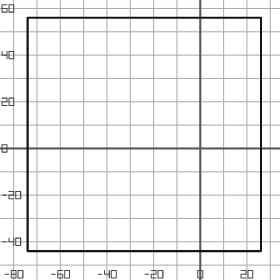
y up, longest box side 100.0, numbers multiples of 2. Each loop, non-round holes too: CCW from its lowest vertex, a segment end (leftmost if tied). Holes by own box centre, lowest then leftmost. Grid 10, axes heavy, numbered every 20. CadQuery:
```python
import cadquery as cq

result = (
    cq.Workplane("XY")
    .moveTo(-74.0, -44.0)
    .lineTo(26.0, -44.0)
    .lineTo(26.0, 56.0)
    .lineTo(-74.0, 56.0)
    .close()
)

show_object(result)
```